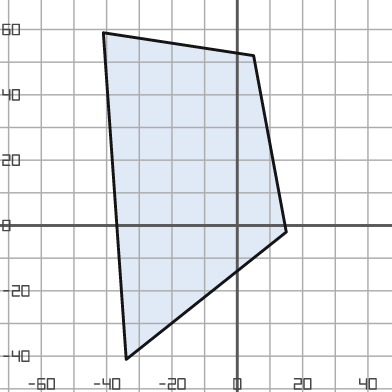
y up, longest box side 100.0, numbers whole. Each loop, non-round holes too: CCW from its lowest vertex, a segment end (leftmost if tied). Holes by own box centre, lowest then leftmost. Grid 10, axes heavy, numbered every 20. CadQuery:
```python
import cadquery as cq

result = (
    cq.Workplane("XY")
    .moveTo(-34.0, -41.0)
    .lineTo(15.0, -2.0)
    .lineTo(5.0, 52.0)
    .lineTo(-41.0, 59.0)
    .close()
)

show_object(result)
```